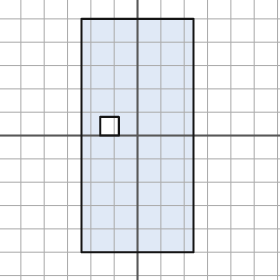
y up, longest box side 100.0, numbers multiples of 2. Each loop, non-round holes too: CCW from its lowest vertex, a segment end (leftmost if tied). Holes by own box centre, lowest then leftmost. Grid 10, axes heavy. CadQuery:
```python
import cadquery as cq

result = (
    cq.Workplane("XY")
    .moveTo(-24.0, -50.0)
    .lineTo(24.0, -50.0)
    .lineTo(24.0, 50.0)
    .lineTo(-24.0, 50.0)
    .close()
    .moveTo(-16.0, 0.0)
    .lineTo(-8.0, 0.0)
    .lineTo(-8.0, 8.0)
    .lineTo(-16.0, 8.0)
    .close()
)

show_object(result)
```